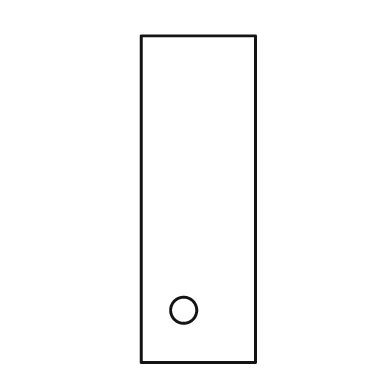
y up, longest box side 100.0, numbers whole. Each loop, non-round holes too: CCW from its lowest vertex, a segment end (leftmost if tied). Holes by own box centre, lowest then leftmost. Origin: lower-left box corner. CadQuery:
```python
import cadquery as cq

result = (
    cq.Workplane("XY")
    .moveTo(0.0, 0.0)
    .lineTo(35.0, 0.0)
    .lineTo(35.0, 100.0)
    .lineTo(0.0, 100.0)
    .close()
    .moveTo(13.0, 16.0)
    .circle(4.0)
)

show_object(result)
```